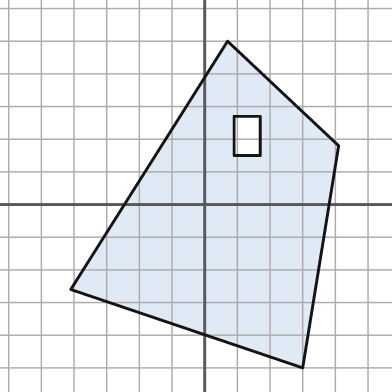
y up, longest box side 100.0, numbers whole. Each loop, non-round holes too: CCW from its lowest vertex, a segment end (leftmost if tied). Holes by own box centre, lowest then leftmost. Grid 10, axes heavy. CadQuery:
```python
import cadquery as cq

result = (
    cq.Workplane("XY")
    .moveTo(30.0, -50.0)
    .lineTo(41.0, 18.0)
    .lineTo(7.0, 50.0)
    .lineTo(-41.0, -26.0)
    .close()
    .moveTo(9.0, 15.0)
    .lineTo(17.0, 15.0)
    .lineTo(17.0, 27.0)
    .lineTo(9.0, 27.0)
    .close()
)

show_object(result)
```